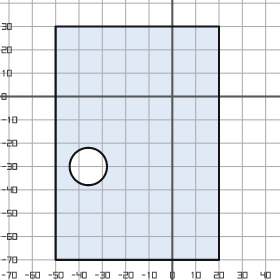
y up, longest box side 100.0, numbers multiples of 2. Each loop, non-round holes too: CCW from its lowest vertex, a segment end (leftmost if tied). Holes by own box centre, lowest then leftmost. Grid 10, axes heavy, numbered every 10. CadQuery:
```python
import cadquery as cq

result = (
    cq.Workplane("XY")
    .moveTo(-50.0, -70.0)
    .lineTo(20.0, -70.0)
    .lineTo(20.0, 30.0)
    .lineTo(-50.0, 30.0)
    .close()
    .moveTo(-36.0, -30.0)
    .circle(8.0)
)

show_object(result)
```